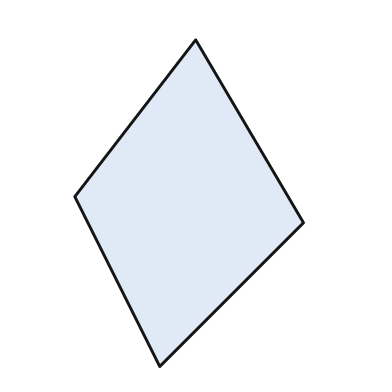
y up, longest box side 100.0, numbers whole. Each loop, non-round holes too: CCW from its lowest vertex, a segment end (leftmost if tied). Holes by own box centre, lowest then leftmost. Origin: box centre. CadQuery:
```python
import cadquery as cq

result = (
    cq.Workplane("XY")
    .moveTo(-9.0, -50.0)
    .lineTo(35.0, -6.0)
    .lineTo(2.0, 50.0)
    .lineTo(-35.0, 2.0)
    .close()
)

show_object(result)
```